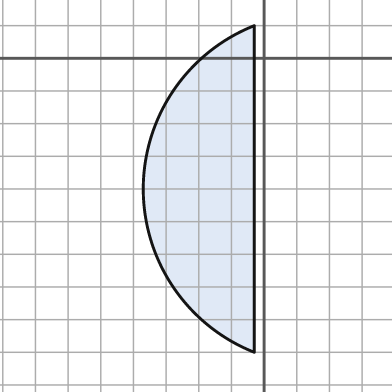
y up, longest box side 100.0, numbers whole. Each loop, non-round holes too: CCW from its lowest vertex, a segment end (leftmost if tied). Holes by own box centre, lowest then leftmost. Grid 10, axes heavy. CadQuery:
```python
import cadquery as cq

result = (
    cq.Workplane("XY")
    .moveTo(-3.0, -90.0)
    .lineTo(-3.0, 10.0)
    .threePointArc((-37.0, -40.0), (-3.0, -90.0))
    .close()
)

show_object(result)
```